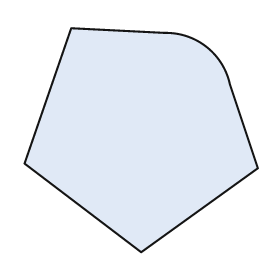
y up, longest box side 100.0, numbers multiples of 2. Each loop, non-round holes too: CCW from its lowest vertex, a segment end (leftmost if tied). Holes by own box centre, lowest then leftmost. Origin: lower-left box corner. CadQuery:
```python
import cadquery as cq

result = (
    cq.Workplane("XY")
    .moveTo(50.0, 0.0)
    .lineTo(100.0, 36.0)
    .lineTo(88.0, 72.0)
    .threePointArc((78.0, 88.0), (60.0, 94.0))
    .lineTo(20.0, 96.0)
    .lineTo(0.0, 38.0)
    .close()
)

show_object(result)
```